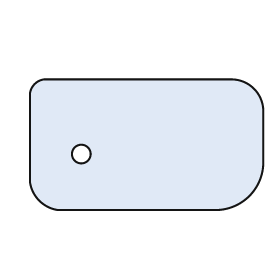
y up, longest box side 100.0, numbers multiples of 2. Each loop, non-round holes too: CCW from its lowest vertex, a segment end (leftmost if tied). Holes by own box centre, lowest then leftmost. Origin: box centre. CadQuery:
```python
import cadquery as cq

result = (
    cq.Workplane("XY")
    .moveTo(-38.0, -28.0)
    .lineTo(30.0, -28.0)
    .threePointArc((44.0, -22.0), (50.0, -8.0))
    .lineTo(50.0, 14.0)
    .threePointArc((46.0, 24.0), (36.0, 28.0))
    .lineTo(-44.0, 28.0)
    .threePointArc((-48.0, 26.0), (-50.0, 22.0))
    .lineTo(-50.0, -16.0)
    .threePointArc((-46.0, -24.0), (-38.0, -28.0))
    .close()
    .moveTo(-28.0, -4.0)
    .circle(4.0)
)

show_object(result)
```